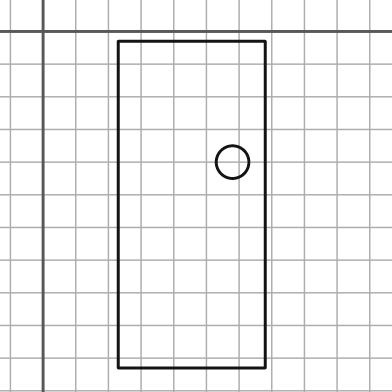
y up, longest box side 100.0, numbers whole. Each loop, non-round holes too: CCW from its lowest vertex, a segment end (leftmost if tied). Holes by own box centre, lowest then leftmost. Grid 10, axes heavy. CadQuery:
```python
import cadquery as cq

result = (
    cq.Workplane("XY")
    .moveTo(23.0, -103.0)
    .lineTo(68.0, -103.0)
    .lineTo(68.0, -3.0)
    .lineTo(23.0, -3.0)
    .close()
    .moveTo(58.0, -40.0)
    .circle(5.0)
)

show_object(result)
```